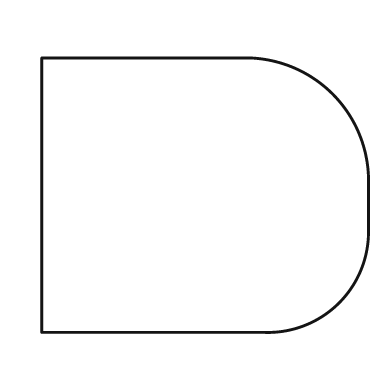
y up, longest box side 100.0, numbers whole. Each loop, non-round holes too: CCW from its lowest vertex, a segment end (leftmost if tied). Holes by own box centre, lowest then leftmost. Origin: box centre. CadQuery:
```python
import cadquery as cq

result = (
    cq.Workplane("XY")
    .moveTo(-50.0, -42.0)
    .lineTo(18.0, -42.0)
    .threePointArc((41.0, -33.0), (50.0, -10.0))
    .lineTo(50.0, 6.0)
    .threePointArc((39.0, 31.0), (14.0, 42.0))
    .lineTo(-50.0, 42.0)
    .close()
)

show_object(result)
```